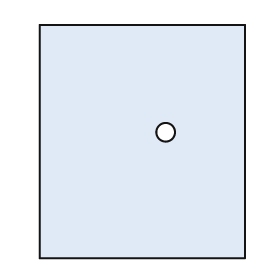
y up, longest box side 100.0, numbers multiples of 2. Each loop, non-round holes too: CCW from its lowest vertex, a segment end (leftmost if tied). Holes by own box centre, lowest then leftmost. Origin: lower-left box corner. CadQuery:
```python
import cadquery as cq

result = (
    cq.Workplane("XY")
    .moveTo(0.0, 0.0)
    .lineTo(88.0, 0.0)
    .lineTo(88.0, 100.0)
    .lineTo(0.0, 100.0)
    .close()
    .moveTo(54.0, 54.0)
    .circle(4.0)
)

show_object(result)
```